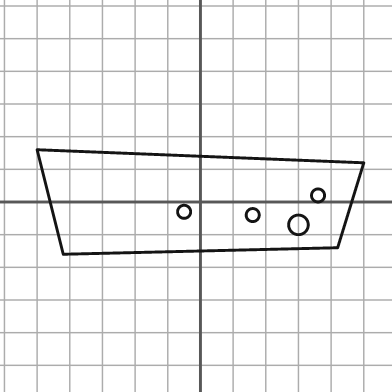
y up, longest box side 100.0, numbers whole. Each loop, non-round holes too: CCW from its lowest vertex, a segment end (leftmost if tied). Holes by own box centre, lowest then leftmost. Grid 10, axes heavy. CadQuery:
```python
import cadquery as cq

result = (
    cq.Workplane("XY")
    .moveTo(-42.0, -16.0)
    .lineTo(42.0, -14.0)
    .lineTo(50.0, 12.0)
    .lineTo(-50.0, 16.0)
    .close()
    .moveTo(30.0, -7.0)
    .circle(3.0)
    .moveTo(16.0, -4.0)
    .circle(2.0)
    .moveTo(-5.0, -3.0)
    .circle(2.0)
    .moveTo(36.0, 2.0)
    .circle(2.0)
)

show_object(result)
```